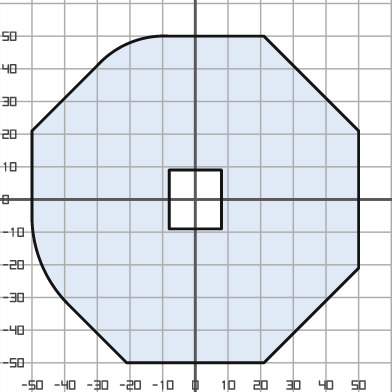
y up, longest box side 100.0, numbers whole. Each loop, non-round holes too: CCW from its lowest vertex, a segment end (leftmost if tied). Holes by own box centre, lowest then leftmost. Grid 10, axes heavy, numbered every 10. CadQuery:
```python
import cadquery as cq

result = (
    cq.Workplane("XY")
    .moveTo(-21.0, -50.0)
    .lineTo(21.0, -50.0)
    .lineTo(50.0, -21.0)
    .lineTo(50.0, 21.0)
    .lineTo(21.0, 50.0)
    .lineTo(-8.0, 50.0)
    .threePointArc((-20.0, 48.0), (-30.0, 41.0))
    .lineTo(-50.0, 21.0)
    .lineTo(-50.0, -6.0)
    .threePointArc((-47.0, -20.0), (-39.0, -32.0))
    .close()
    .moveTo(-8.0, -9.0)
    .lineTo(8.0, -9.0)
    .lineTo(8.0, 9.0)
    .lineTo(-8.0, 9.0)
    .close()
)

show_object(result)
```